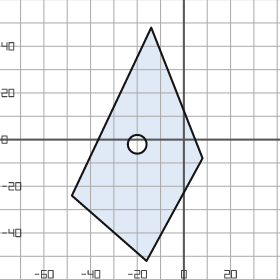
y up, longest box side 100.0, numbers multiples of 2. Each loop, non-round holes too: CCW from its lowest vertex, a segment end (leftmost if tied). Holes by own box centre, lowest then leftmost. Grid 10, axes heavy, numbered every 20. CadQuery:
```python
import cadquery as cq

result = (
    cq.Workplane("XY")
    .moveTo(-16.0, -52.0)
    .lineTo(8.0, -8.0)
    .lineTo(-14.0, 48.0)
    .lineTo(-48.0, -24.0)
    .close()
    .moveTo(-20.0, -2.0)
    .circle(4.0)
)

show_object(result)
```